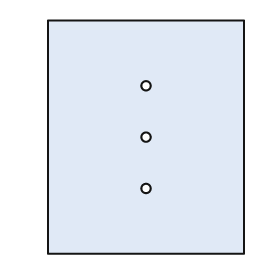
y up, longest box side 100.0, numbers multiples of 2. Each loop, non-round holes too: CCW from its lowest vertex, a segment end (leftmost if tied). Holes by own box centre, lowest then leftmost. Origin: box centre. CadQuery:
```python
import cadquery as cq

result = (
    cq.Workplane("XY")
    .moveTo(-42.0, -50.0)
    .lineTo(42.0, -50.0)
    .lineTo(42.0, 50.0)
    .lineTo(-42.0, 50.0)
    .close()
    .moveTo(0.0, -22.0)
    .circle(2.0)
    .moveTo(0.0, 0.0)
    .circle(2.0)
    .moveTo(0.0, 22.0)
    .circle(2.0)
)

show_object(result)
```